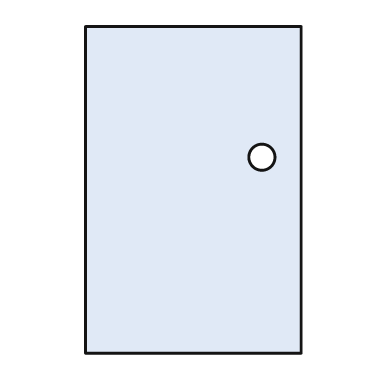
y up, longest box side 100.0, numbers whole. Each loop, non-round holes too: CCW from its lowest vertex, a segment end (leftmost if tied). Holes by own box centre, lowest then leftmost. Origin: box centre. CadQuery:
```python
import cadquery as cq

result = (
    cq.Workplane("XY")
    .moveTo(-33.0, -50.0)
    .lineTo(33.0, -50.0)
    .lineTo(33.0, 50.0)
    .lineTo(-33.0, 50.0)
    .close()
    .moveTo(21.0, 10.0)
    .circle(4.0)
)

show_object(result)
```